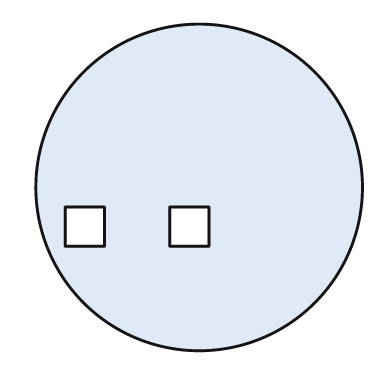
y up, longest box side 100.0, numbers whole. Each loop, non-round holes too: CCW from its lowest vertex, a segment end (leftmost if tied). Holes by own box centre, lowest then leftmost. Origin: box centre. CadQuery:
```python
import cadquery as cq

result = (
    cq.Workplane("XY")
    .moveTo(0.0, 0.0)
    .circle(50.0)
    .moveTo(-41.0, -18.0)
    .lineTo(-29.0, -18.0)
    .lineTo(-29.0, -6.0)
    .lineTo(-41.0, -6.0)
    .close()
    .moveTo(-9.0, -18.0)
    .lineTo(3.0, -18.0)
    .lineTo(3.0, -6.0)
    .lineTo(-9.0, -6.0)
    .close()
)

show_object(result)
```